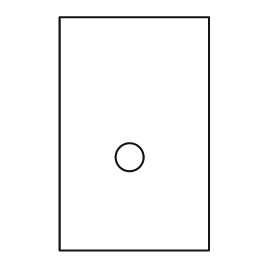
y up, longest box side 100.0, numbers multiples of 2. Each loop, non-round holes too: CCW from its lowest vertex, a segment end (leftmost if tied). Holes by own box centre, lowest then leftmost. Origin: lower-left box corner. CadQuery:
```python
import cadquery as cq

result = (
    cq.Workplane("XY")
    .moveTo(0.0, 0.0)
    .lineTo(64.0, 0.0)
    .lineTo(64.0, 100.0)
    .lineTo(0.0, 100.0)
    .close()
    .moveTo(30.0, 40.0)
    .circle(6.0)
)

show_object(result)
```